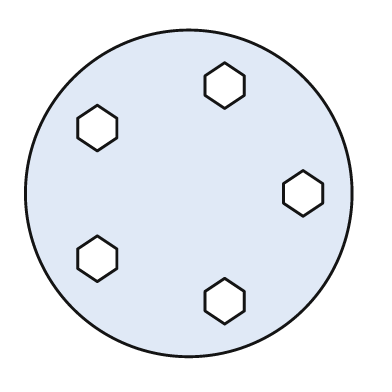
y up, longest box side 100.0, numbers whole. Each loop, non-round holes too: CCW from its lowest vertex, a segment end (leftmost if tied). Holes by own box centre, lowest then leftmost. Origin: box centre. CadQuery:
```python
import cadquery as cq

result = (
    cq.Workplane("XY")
    .moveTo(0.0, 0.0)
    .circle(50.0)
    .moveTo(11.0, -40.0)
    .lineTo(17.0, -36.0)
    .lineTo(17.0, -30.0)
    .lineTo(11.0, -26.0)
    .lineTo(5.0, -30.0)
    .lineTo(5.0, -36.0)
    .close()
    .moveTo(-28.0, -27.0)
    .lineTo(-22.0, -23.0)
    .lineTo(-22.0, -17.0)
    .lineTo(-28.0, -13.0)
    .lineTo(-34.0, -17.0)
    .lineTo(-34.0, -23.0)
    .close()
    .moveTo(35.0, -7.0)
    .lineTo(41.0, -3.0)
    .lineTo(41.0, 3.0)
    .lineTo(35.0, 7.0)
    .lineTo(29.0, 3.0)
    .lineTo(29.0, -3.0)
    .close()
    .moveTo(-28.0, 13.0)
    .lineTo(-22.0, 17.0)
    .lineTo(-22.0, 23.0)
    .lineTo(-28.0, 27.0)
    .lineTo(-34.0, 23.0)
    .lineTo(-34.0, 17.0)
    .close()
    .moveTo(11.0, 26.0)
    .lineTo(17.0, 30.0)
    .lineTo(17.0, 36.0)
    .lineTo(11.0, 40.0)
    .lineTo(5.0, 36.0)
    .lineTo(5.0, 30.0)
    .close()
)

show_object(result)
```